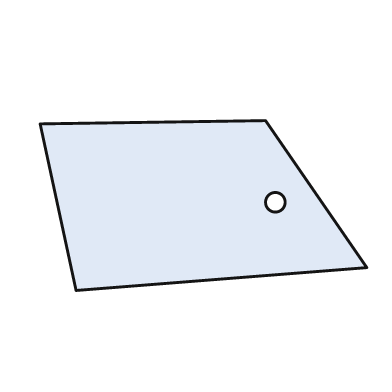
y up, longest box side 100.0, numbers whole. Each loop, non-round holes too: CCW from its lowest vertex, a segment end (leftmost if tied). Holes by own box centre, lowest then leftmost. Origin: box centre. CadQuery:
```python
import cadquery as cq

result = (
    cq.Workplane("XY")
    .moveTo(-39.0, -26.0)
    .lineTo(50.0, -19.0)
    .lineTo(19.0, 26.0)
    .lineTo(-50.0, 25.0)
    .close()
    .moveTo(22.0, 1.0)
    .circle(3.0)
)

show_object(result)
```